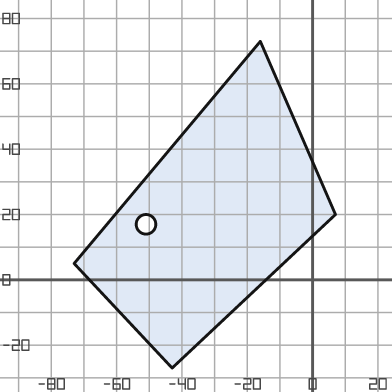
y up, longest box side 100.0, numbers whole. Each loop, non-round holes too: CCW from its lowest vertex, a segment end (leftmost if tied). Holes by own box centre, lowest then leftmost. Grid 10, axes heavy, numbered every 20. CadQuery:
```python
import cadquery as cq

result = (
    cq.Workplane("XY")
    .moveTo(-43.0, -27.0)
    .lineTo(7.0, 20.0)
    .lineTo(-16.0, 73.0)
    .lineTo(-73.0, 5.0)
    .close()
    .moveTo(-51.0, 17.0)
    .circle(3.0)
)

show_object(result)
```